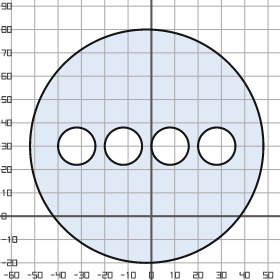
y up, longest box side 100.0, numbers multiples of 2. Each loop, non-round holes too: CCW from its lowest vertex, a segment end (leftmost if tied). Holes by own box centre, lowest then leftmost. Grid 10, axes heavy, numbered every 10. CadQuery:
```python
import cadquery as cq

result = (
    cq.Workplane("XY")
    .moveTo(-2.0, 30.0)
    .circle(50.0)
    .moveTo(-32.0, 30.0)
    .circle(8.0)
    .moveTo(-12.0, 30.0)
    .circle(8.0)
    .moveTo(8.0, 30.0)
    .circle(8.0)
    .moveTo(28.0, 30.0)
    .circle(8.0)
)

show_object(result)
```